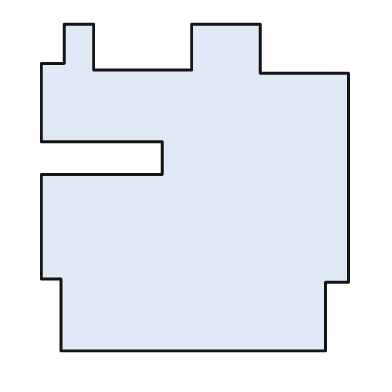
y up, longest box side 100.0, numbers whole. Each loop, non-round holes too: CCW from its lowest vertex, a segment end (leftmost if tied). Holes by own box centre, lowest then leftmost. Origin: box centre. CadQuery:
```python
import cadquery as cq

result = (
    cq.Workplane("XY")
    .moveTo(-41.0, -50.0)
    .lineTo(40.0, -50.0)
    .lineTo(40.0, -29.0)
    .lineTo(47.0, -29.0)
    .lineTo(47.0, 35.0)
    .lineTo(20.0, 35.0)
    .lineTo(20.0, 50.0)
    .lineTo(-1.0, 50.0)
    .lineTo(-1.0, 36.0)
    .lineTo(-31.0, 36.0)
    .lineTo(-31.0, 50.0)
    .lineTo(-40.0, 50.0)
    .lineTo(-40.0, 38.0)
    .lineTo(-47.0, 38.0)
    .lineTo(-47.0, 14.0)
    .lineTo(-10.0, 14.0)
    .lineTo(-10.0, 4.0)
    .lineTo(-47.0, 4.0)
    .lineTo(-47.0, -28.0)
    .lineTo(-41.0, -28.0)
    .close()
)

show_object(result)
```